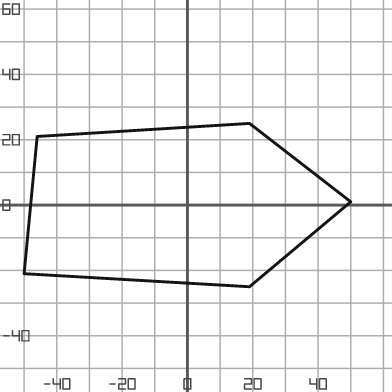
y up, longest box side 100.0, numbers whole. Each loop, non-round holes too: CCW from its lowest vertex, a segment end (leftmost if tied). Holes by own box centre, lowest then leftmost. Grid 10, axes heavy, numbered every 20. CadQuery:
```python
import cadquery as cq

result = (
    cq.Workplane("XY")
    .moveTo(19.0, -25.0)
    .lineTo(50.0, 1.0)
    .lineTo(19.0, 25.0)
    .lineTo(-46.0, 21.0)
    .lineTo(-50.0, -21.0)
    .close()
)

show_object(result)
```